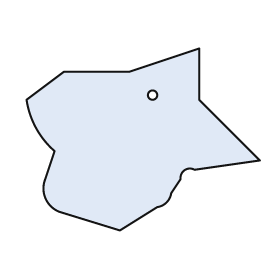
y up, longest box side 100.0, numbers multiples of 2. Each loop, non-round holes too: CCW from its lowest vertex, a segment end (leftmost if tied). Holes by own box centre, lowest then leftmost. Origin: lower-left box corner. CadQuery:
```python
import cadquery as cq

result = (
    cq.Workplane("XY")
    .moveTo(40.0, 0.0)
    .lineTo(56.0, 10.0)
    .threePointArc((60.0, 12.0), (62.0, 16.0))
    .lineTo(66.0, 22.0)
    .threePointArc((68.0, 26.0), (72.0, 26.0))
    .lineTo(100.0, 30.0)
    .lineTo(74.0, 56.0)
    .lineTo(74.0, 78.0)
    .lineTo(44.0, 68.0)
    .lineTo(16.0, 68.0)
    .lineTo(0.0, 56.0)
    .threePointArc((4.0, 44.0), (12.0, 34.0))
    .lineTo(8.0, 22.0)
    .threePointArc((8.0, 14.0), (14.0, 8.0))
    .close()
    .moveTo(54.0, 58.0)
    .circle(2.0)
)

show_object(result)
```